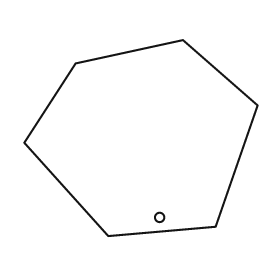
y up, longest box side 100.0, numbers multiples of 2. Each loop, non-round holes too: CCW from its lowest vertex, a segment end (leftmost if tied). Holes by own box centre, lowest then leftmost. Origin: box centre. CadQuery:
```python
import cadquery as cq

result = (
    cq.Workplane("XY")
    .moveTo(-14.0, -42.0)
    .lineTo(32.0, -38.0)
    .lineTo(50.0, 14.0)
    .lineTo(18.0, 42.0)
    .lineTo(-28.0, 32.0)
    .lineTo(-50.0, -2.0)
    .close()
    .moveTo(8.0, -34.0)
    .circle(2.0)
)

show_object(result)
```